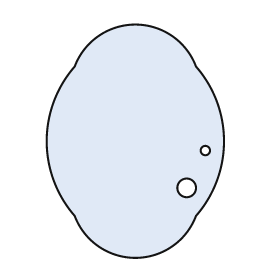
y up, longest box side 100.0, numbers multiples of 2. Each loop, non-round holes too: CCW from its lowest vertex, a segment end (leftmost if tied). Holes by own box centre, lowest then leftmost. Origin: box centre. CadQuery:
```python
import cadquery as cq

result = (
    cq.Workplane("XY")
    .moveTo(-26.0, -32.0)
    .threePointArc((0.0, -50.0), (26.0, -32.0))
    .threePointArc((38.0, 0.0), (26.0, 32.0))
    .threePointArc((0.0, 50.0), (-26.0, 32.0))
    .threePointArc((-38.0, 0.0), (-26.0, -32.0))
    .close()
    .moveTo(22.0, -20.0)
    .circle(4.0)
    .moveTo(30.0, -4.0)
    .circle(2.0)
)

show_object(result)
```